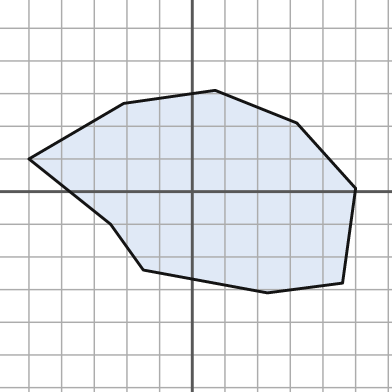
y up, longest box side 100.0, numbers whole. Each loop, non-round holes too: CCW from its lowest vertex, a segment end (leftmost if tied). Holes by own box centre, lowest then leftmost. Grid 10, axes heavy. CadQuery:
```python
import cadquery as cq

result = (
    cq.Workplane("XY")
    .moveTo(23.0, -31.0)
    .lineTo(46.0, -28.0)
    .lineTo(50.0, 1.0)
    .lineTo(32.0, 21.0)
    .lineTo(7.0, 31.0)
    .lineTo(-21.0, 27.0)
    .lineTo(-50.0, 10.0)
    .lineTo(-25.0, -10.0)
    .lineTo(-15.0, -24.0)
    .close()
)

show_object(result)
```